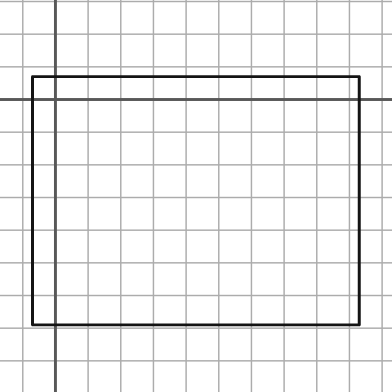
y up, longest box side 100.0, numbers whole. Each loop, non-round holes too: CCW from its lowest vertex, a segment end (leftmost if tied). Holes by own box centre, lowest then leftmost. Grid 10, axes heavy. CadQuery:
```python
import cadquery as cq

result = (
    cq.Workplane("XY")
    .moveTo(-7.0, -69.0)
    .lineTo(93.0, -69.0)
    .lineTo(93.0, 7.0)
    .lineTo(-7.0, 7.0)
    .close()
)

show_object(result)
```